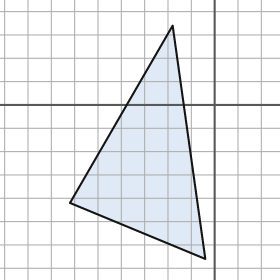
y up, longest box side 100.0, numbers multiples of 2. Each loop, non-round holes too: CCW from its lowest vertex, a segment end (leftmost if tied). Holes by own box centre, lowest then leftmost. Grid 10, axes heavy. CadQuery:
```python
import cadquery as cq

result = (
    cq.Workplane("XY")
    .moveTo(-4.0, -66.0)
    .lineTo(-18.0, 34.0)
    .lineTo(-62.0, -42.0)
    .close()
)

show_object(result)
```